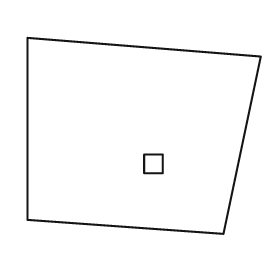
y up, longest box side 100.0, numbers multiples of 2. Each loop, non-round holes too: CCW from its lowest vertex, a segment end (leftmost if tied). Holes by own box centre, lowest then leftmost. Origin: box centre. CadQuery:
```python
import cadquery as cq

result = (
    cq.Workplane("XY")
    .moveTo(34.0, -42.0)
    .lineTo(50.0, 34.0)
    .lineTo(-50.0, 42.0)
    .lineTo(-50.0, -36.0)
    .close()
    .moveTo(0.0, -16.0)
    .lineTo(8.0, -16.0)
    .lineTo(8.0, -8.0)
    .lineTo(0.0, -8.0)
    .close()
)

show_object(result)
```